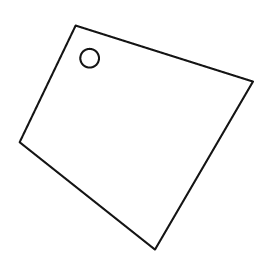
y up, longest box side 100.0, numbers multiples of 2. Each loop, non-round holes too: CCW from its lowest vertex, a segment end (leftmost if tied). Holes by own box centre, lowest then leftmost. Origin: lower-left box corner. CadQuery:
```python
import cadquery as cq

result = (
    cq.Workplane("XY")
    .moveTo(58.0, 0.0)
    .lineTo(100.0, 72.0)
    .lineTo(24.0, 96.0)
    .lineTo(0.0, 46.0)
    .close()
    .moveTo(30.0, 82.0)
    .circle(4.0)
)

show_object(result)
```